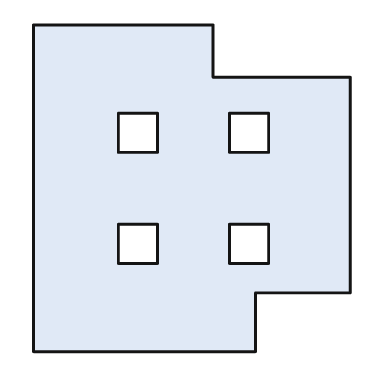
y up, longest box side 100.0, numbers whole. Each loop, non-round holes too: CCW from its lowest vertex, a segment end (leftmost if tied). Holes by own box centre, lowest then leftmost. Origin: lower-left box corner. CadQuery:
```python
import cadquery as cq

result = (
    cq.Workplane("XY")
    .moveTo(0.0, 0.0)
    .lineTo(68.0, 0.0)
    .lineTo(68.0, 18.0)
    .lineTo(97.0, 18.0)
    .lineTo(97.0, 84.0)
    .lineTo(55.0, 84.0)
    .lineTo(55.0, 100.0)
    .lineTo(0.0, 100.0)
    .close()
    .moveTo(26.0, 27.0)
    .lineTo(38.0, 27.0)
    .lineTo(38.0, 39.0)
    .lineTo(26.0, 39.0)
    .close()
    .moveTo(60.0, 27.0)
    .lineTo(72.0, 27.0)
    .lineTo(72.0, 39.0)
    .lineTo(60.0, 39.0)
    .close()
    .moveTo(26.0, 61.0)
    .lineTo(38.0, 61.0)
    .lineTo(38.0, 73.0)
    .lineTo(26.0, 73.0)
    .close()
    .moveTo(60.0, 61.0)
    .lineTo(72.0, 61.0)
    .lineTo(72.0, 73.0)
    .lineTo(60.0, 73.0)
    .close()
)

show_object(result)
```